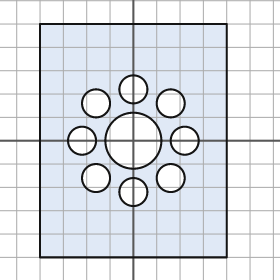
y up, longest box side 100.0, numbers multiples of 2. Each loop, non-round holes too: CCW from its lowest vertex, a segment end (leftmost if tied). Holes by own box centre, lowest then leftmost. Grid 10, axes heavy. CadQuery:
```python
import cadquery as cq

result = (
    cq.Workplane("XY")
    .moveTo(-40.0, -50.0)
    .lineTo(40.0, -50.0)
    .lineTo(40.0, 50.0)
    .lineTo(-40.0, 50.0)
    .close()
    .moveTo(0.0, -22.0)
    .circle(6.0)
    .moveTo(-16.0, -16.0)
    .circle(6.0)
    .moveTo(16.0, -16.0)
    .circle(6.0)
    .moveTo(-22.0, 0.0)
    .circle(6.0)
    .moveTo(0.0, 0.0)
    .circle(12.0)
    .moveTo(22.0, 0.0)
    .circle(6.0)
    .moveTo(-16.0, 16.0)
    .circle(6.0)
    .moveTo(16.0, 16.0)
    .circle(6.0)
    .moveTo(0.0, 22.0)
    .circle(6.0)
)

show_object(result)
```